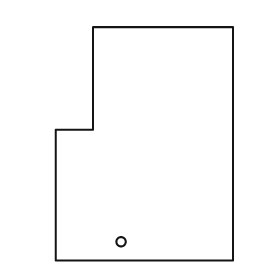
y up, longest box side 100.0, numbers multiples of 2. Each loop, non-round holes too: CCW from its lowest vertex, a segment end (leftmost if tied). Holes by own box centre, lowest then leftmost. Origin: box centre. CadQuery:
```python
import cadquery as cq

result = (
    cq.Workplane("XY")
    .moveTo(-38.0, -50.0)
    .lineTo(38.0, -50.0)
    .lineTo(38.0, 50.0)
    .lineTo(-22.0, 50.0)
    .lineTo(-22.0, 6.0)
    .lineTo(-38.0, 6.0)
    .close()
    .moveTo(-10.0, -42.0)
    .circle(2.0)
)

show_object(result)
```